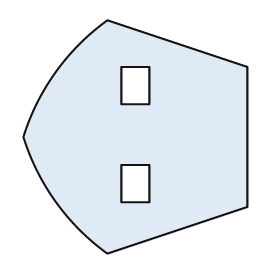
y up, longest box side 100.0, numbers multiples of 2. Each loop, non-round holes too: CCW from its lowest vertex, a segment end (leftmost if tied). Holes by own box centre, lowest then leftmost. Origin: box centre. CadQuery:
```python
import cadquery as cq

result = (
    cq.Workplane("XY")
    .moveTo(-12.0, -50.0)
    .lineTo(48.0, -30.0)
    .lineTo(48.0, 30.0)
    .lineTo(-12.0, 50.0)
    .threePointArc((-34.0, 28.0), (-48.0, 0.0))
    .threePointArc((-34.0, -28.0), (-12.0, -50.0))
    .close()
    .moveTo(-6.0, -28.0)
    .lineTo(6.0, -28.0)
    .lineTo(6.0, -12.0)
    .lineTo(-6.0, -12.0)
    .close()
    .moveTo(-6.0, 14.0)
    .lineTo(6.0, 14.0)
    .lineTo(6.0, 30.0)
    .lineTo(-6.0, 30.0)
    .close()
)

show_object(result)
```